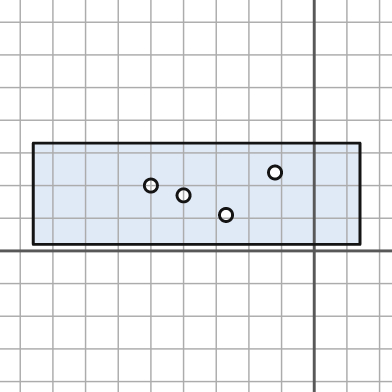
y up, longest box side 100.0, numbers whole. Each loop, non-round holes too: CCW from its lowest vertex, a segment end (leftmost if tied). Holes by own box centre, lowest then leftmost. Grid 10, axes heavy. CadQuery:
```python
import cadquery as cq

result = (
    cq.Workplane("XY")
    .moveTo(-86.0, 2.0)
    .lineTo(14.0, 2.0)
    .lineTo(14.0, 33.0)
    .lineTo(-86.0, 33.0)
    .close()
    .moveTo(-27.0, 11.0)
    .circle(2.0)
    .moveTo(-40.0, 17.0)
    .circle(2.0)
    .moveTo(-50.0, 20.0)
    .circle(2.0)
    .moveTo(-12.0, 24.0)
    .circle(2.0)
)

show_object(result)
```